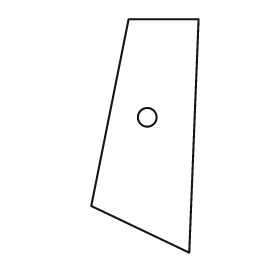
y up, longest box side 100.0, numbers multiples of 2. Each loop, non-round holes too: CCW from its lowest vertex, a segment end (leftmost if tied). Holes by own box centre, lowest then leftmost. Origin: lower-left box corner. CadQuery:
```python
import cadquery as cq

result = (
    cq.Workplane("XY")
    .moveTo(42.0, 0.0)
    .lineTo(46.0, 100.0)
    .lineTo(16.0, 100.0)
    .lineTo(0.0, 20.0)
    .close()
    .moveTo(24.0, 58.0)
    .circle(4.0)
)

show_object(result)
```